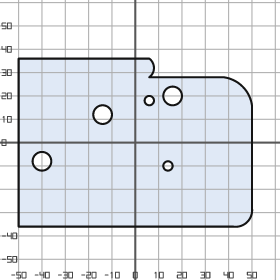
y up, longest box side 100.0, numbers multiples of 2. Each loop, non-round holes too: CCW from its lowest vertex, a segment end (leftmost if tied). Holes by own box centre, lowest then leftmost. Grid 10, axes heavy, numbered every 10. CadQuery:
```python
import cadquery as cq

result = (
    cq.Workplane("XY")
    .moveTo(-50.0, -36.0)
    .lineTo(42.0, -36.0)
    .threePointArc((48.0, -34.0), (50.0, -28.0))
    .lineTo(50.0, 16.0)
    .threePointArc((46.0, 24.0), (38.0, 28.0))
    .lineTo(6.0, 28.0)
    .threePointArc((8.0, 32.0), (6.0, 36.0))
    .lineTo(-50.0, 36.0)
    .close()
    .moveTo(14.0, -10.0)
    .circle(2.0)
    .moveTo(-40.0, -8.0)
    .circle(4.0)
    .moveTo(-14.0, 12.0)
    .circle(4.0)
    .moveTo(6.0, 18.0)
    .circle(2.0)
    .moveTo(16.0, 20.0)
    .circle(4.0)
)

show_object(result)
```